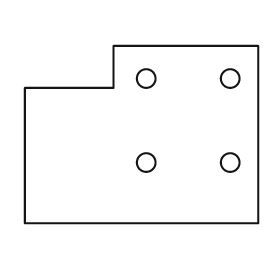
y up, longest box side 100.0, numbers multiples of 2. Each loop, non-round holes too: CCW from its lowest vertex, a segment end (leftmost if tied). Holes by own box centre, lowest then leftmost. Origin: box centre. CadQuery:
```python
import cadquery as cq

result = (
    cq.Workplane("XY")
    .moveTo(-50.0, -38.0)
    .lineTo(50.0, -38.0)
    .lineTo(50.0, 38.0)
    .lineTo(-12.0, 38.0)
    .lineTo(-12.0, 20.0)
    .lineTo(-50.0, 20.0)
    .close()
    .moveTo(2.0, -12.0)
    .circle(4.0)
    .moveTo(38.0, -12.0)
    .circle(4.0)
    .moveTo(2.0, 24.0)
    .circle(4.0)
    .moveTo(38.0, 24.0)
    .circle(4.0)
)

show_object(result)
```